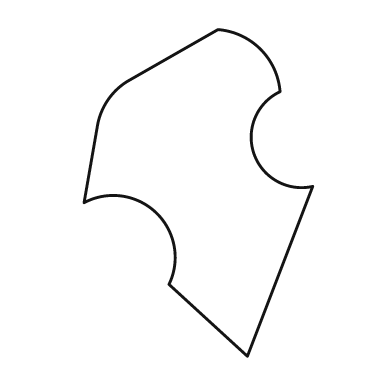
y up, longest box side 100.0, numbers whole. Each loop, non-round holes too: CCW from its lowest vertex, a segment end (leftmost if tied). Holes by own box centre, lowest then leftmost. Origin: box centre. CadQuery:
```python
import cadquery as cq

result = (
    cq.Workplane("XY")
    .moveTo(15.0, -50.0)
    .lineTo(35.0, 2.0)
    .threePointArc((17.0, 12.0), (25.0, 31.0))
    .threePointArc((19.0, 44.0), (6.0, 50.0))
    .lineTo(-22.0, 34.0)
    .threePointArc((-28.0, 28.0), (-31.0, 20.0))
    .lineTo(-35.0, -3.0)
    .threePointArc((-13.0, -6.0), (-9.0, -28.0))
    .close()
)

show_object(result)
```